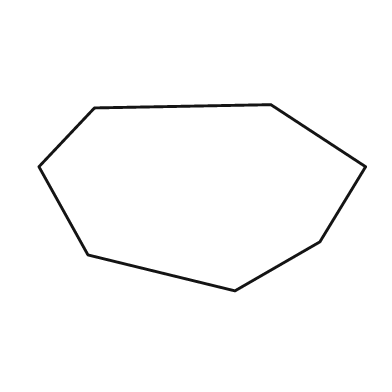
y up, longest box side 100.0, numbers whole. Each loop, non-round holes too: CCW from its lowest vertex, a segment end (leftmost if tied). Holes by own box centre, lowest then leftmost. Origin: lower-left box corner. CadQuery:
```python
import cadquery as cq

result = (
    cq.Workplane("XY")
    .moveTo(60.0, 0.0)
    .lineTo(86.0, 15.0)
    .lineTo(100.0, 38.0)
    .lineTo(71.0, 57.0)
    .lineTo(17.0, 56.0)
    .lineTo(0.0, 38.0)
    .lineTo(15.0, 11.0)
    .close()
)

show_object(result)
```